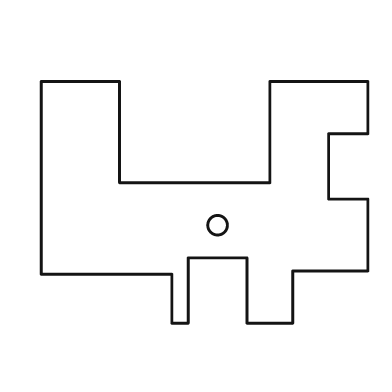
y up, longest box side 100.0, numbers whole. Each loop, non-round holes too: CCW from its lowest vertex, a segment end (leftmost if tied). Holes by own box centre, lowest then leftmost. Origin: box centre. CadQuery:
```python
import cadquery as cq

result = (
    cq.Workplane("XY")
    .moveTo(-10.0, -37.0)
    .lineTo(-5.0, -37.0)
    .lineTo(-5.0, -17.0)
    .lineTo(13.0, -17.0)
    .lineTo(13.0, -37.0)
    .lineTo(27.0, -37.0)
    .lineTo(27.0, -21.0)
    .lineTo(50.0, -21.0)
    .lineTo(50.0, 1.0)
    .lineTo(38.0, 1.0)
    .lineTo(38.0, 21.0)
    .lineTo(50.0, 21.0)
    .lineTo(50.0, 37.0)
    .lineTo(20.0, 37.0)
    .lineTo(20.0, 6.0)
    .lineTo(-26.0, 6.0)
    .lineTo(-26.0, 37.0)
    .lineTo(-50.0, 37.0)
    .lineTo(-50.0, -22.0)
    .lineTo(-10.0, -22.0)
    .close()
    .moveTo(4.0, -7.0)
    .circle(3.0)
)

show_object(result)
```